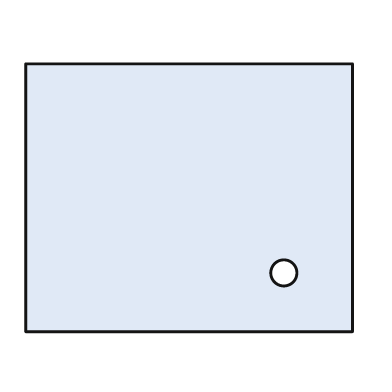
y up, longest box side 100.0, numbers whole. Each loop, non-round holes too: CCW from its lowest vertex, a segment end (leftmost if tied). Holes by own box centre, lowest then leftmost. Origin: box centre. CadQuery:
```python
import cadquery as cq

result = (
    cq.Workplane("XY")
    .moveTo(-50.0, -41.0)
    .lineTo(50.0, -41.0)
    .lineTo(50.0, 41.0)
    .lineTo(-50.0, 41.0)
    .close()
    .moveTo(29.0, -23.0)
    .circle(4.0)
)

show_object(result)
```